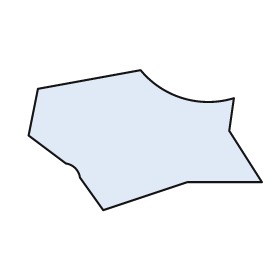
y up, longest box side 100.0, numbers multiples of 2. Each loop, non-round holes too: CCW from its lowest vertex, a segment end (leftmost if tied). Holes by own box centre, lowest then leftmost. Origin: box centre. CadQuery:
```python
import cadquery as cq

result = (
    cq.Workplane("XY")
    .moveTo(-18.0, -30.0)
    .lineTo(18.0, -18.0)
    .lineTo(50.0, -18.0)
    .lineTo(36.0, 4.0)
    .lineTo(38.0, 18.0)
    .threePointArc((16.0, 18.0), (-2.0, 30.0))
    .lineTo(-46.0, 22.0)
    .lineTo(-50.0, 2.0)
    .lineTo(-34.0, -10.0)
    .threePointArc((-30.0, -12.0), (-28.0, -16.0))
    .close()
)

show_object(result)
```